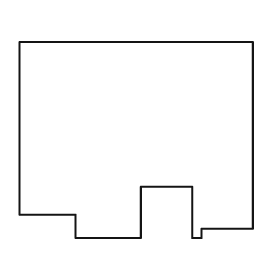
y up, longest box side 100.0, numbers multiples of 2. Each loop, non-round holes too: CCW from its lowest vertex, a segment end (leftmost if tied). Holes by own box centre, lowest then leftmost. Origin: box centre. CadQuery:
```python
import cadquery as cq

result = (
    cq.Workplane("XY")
    .moveTo(-26.0, -42.0)
    .lineTo(2.0, -42.0)
    .lineTo(2.0, -20.0)
    .lineTo(24.0, -20.0)
    .lineTo(24.0, -42.0)
    .lineTo(28.0, -42.0)
    .lineTo(28.0, -38.0)
    .lineTo(50.0, -38.0)
    .lineTo(50.0, 42.0)
    .lineTo(-50.0, 42.0)
    .lineTo(-50.0, -32.0)
    .lineTo(-26.0, -32.0)
    .close()
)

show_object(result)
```